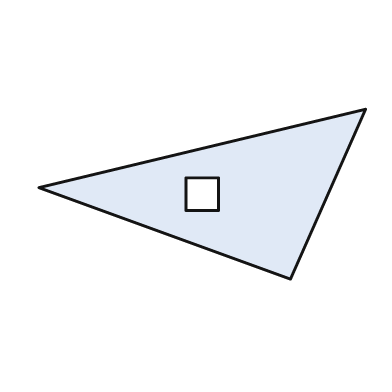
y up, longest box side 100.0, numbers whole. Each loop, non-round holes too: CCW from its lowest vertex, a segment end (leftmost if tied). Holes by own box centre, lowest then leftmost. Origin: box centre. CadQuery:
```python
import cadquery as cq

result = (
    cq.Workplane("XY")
    .moveTo(27.0, -26.0)
    .lineTo(50.0, 26.0)
    .lineTo(-50.0, 2.0)
    .close()
    .moveTo(-5.0, -5.0)
    .lineTo(5.0, -5.0)
    .lineTo(5.0, 5.0)
    .lineTo(-5.0, 5.0)
    .close()
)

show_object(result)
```